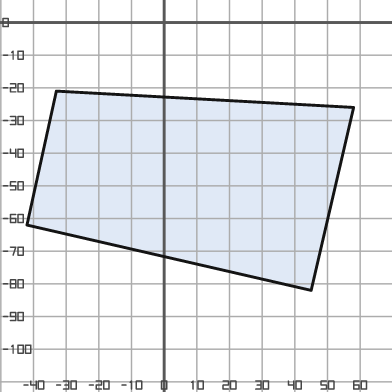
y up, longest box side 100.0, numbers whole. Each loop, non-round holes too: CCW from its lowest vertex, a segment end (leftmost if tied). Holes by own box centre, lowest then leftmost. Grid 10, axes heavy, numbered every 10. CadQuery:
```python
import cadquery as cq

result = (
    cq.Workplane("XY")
    .moveTo(45.0, -82.0)
    .lineTo(58.0, -26.0)
    .lineTo(-33.0, -21.0)
    .lineTo(-42.0, -62.0)
    .close()
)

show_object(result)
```